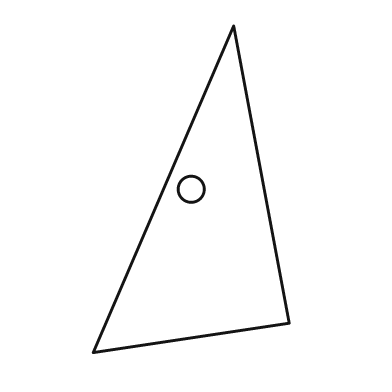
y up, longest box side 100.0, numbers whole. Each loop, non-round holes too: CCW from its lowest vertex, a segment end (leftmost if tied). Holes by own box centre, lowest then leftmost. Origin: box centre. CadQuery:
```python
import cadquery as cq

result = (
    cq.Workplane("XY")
    .moveTo(-30.0, -50.0)
    .lineTo(30.0, -41.0)
    .lineTo(13.0, 50.0)
    .close()
    .moveTo(0.0, 0.0)
    .circle(4.0)
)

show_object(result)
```